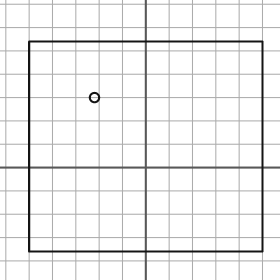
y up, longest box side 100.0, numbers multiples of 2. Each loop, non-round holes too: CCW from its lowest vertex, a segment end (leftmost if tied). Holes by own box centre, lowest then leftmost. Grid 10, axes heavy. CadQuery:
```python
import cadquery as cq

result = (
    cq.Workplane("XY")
    .moveTo(-50.0, -36.0)
    .lineTo(50.0, -36.0)
    .lineTo(50.0, 54.0)
    .lineTo(-50.0, 54.0)
    .close()
    .moveTo(-22.0, 30.0)
    .circle(2.0)
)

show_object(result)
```